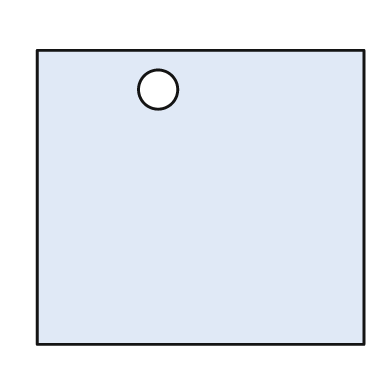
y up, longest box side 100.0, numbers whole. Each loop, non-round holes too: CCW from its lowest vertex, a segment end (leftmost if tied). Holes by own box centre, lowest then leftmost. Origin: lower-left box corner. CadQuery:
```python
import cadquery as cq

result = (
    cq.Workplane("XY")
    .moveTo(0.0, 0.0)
    .lineTo(100.0, 0.0)
    .lineTo(100.0, 90.0)
    .lineTo(0.0, 90.0)
    .close()
    .moveTo(37.0, 78.0)
    .circle(6.0)
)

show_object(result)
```